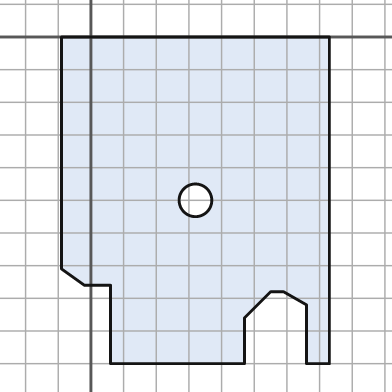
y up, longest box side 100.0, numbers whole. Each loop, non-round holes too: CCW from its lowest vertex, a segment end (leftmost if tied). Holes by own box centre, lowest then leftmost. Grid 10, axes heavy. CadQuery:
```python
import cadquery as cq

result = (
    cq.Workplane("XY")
    .moveTo(6.0, -100.0)
    .lineTo(47.0, -100.0)
    .lineTo(47.0, -86.0)
    .lineTo(55.0, -78.0)
    .lineTo(59.0, -78.0)
    .lineTo(66.0, -82.0)
    .lineTo(66.0, -100.0)
    .lineTo(73.0, -100.0)
    .lineTo(73.0, 0.0)
    .lineTo(-9.0, 0.0)
    .lineTo(-9.0, -71.0)
    .lineTo(-2.0, -76.0)
    .lineTo(6.0, -76.0)
    .close()
    .moveTo(32.0, -50.0)
    .circle(5.0)
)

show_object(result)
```